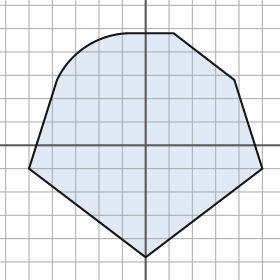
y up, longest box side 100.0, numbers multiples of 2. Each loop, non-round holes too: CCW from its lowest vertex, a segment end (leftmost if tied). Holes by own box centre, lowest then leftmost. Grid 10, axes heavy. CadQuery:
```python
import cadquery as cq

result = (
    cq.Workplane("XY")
    .moveTo(0.0, -48.0)
    .lineTo(50.0, -10.0)
    .lineTo(38.0, 28.0)
    .lineTo(12.0, 48.0)
    .lineTo(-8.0, 48.0)
    .threePointArc((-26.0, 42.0), (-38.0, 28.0))
    .lineTo(-50.0, -10.0)
    .close()
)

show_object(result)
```